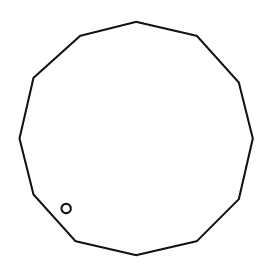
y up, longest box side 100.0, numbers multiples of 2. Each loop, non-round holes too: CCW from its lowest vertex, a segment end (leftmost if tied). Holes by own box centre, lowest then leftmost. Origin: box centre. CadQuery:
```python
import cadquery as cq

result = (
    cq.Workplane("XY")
    .moveTo(0.0, -50.0)
    .lineTo(26.0, -44.0)
    .lineTo(44.0, -26.0)
    .lineTo(50.0, 0.0)
    .lineTo(44.0, 24.0)
    .lineTo(26.0, 44.0)
    .lineTo(0.0, 50.0)
    .lineTo(-24.0, 44.0)
    .lineTo(-44.0, 26.0)
    .lineTo(-50.0, 0.0)
    .lineTo(-44.0, -24.0)
    .lineTo(-26.0, -44.0)
    .close()
    .moveTo(-30.0, -30.0)
    .circle(2.0)
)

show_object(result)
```